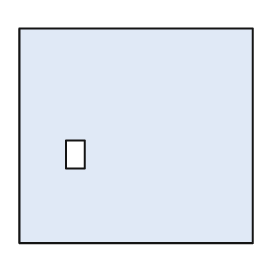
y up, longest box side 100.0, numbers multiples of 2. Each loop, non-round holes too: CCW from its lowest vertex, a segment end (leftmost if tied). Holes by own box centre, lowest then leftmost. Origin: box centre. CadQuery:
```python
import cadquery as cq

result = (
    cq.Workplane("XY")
    .moveTo(-50.0, -46.0)
    .lineTo(50.0, -46.0)
    .lineTo(50.0, 46.0)
    .lineTo(-50.0, 46.0)
    .close()
    .moveTo(-30.0, -14.0)
    .lineTo(-22.0, -14.0)
    .lineTo(-22.0, -2.0)
    .lineTo(-30.0, -2.0)
    .close()
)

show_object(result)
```